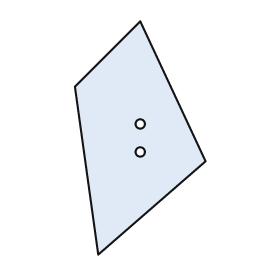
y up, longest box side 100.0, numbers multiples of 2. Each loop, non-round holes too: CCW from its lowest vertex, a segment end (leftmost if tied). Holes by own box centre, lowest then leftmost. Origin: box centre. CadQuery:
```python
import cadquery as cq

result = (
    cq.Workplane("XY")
    .moveTo(-18.0, -50.0)
    .lineTo(28.0, -10.0)
    .lineTo(0.0, 50.0)
    .lineTo(-28.0, 22.0)
    .close()
    .moveTo(0.0, -6.0)
    .circle(2.0)
    .moveTo(0.0, 6.0)
    .circle(2.0)
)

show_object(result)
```